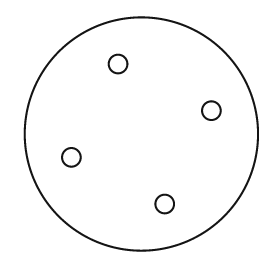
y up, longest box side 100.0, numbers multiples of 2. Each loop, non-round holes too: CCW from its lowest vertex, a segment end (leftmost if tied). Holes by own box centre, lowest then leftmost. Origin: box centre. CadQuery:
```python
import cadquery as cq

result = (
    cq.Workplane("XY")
    .moveTo(0.0, 0.0)
    .circle(50.0)
    .moveTo(10.0, -30.0)
    .circle(4.0)
    .moveTo(-30.0, -10.0)
    .circle(4.0)
    .moveTo(30.0, 10.0)
    .circle(4.0)
    .moveTo(-10.0, 30.0)
    .circle(4.0)
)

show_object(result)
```